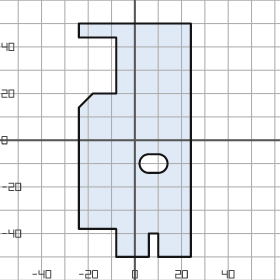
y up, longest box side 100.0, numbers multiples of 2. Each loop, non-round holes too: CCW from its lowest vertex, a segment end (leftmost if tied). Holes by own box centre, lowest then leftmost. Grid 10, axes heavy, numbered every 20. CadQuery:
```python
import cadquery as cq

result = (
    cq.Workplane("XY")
    .moveTo(-8.0, -50.0)
    .lineTo(6.0, -50.0)
    .lineTo(6.0, -40.0)
    .lineTo(10.0, -40.0)
    .lineTo(10.0, -50.0)
    .lineTo(24.0, -50.0)
    .lineTo(24.0, 50.0)
    .lineTo(-24.0, 50.0)
    .lineTo(-24.0, 44.0)
    .lineTo(-8.0, 44.0)
    .lineTo(-8.0, 20.0)
    .lineTo(-18.0, 20.0)
    .lineTo(-24.0, 14.0)
    .lineTo(-24.0, -38.0)
    .lineTo(-8.0, -38.0)
    .close()
    .moveTo(6.0, -14.0)
    .lineTo(10.0, -14.0)
    .threePointArc((14.0, -10.0), (10.0, -6.0))
    .lineTo(6.0, -6.0)
    .threePointArc((2.0, -10.0), (6.0, -14.0))
    .close()
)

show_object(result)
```